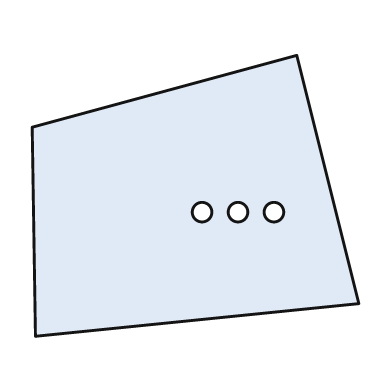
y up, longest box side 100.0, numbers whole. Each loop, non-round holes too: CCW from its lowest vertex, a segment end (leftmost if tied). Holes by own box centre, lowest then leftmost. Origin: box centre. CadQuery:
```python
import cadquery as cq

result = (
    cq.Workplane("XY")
    .moveTo(-49.0, -43.0)
    .lineTo(50.0, -33.0)
    .lineTo(31.0, 43.0)
    .lineTo(-50.0, 21.0)
    .close()
    .moveTo(2.0, -5.0)
    .circle(3.0)
    .moveTo(13.0, -5.0)
    .circle(3.0)
    .moveTo(24.0, -5.0)
    .circle(3.0)
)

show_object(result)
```